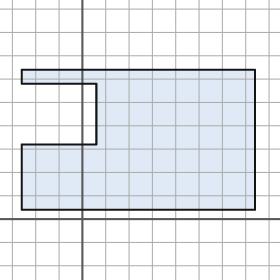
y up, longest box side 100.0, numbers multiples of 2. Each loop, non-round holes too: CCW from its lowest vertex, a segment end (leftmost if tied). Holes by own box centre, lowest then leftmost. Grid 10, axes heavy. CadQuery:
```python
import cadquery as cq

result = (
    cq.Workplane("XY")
    .moveTo(-26.0, 4.0)
    .lineTo(74.0, 4.0)
    .lineTo(74.0, 64.0)
    .lineTo(-26.0, 64.0)
    .lineTo(-26.0, 58.0)
    .lineTo(6.0, 58.0)
    .lineTo(6.0, 32.0)
    .lineTo(-26.0, 32.0)
    .close()
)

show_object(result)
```